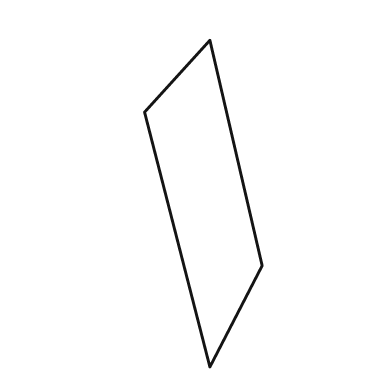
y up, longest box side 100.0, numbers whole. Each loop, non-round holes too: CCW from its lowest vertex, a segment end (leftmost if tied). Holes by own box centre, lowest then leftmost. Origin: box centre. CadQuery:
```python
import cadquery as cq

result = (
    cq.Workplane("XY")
    .moveTo(2.0, -50.0)
    .lineTo(18.0, -19.0)
    .lineTo(2.0, 50.0)
    .lineTo(-18.0, 28.0)
    .close()
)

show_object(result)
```